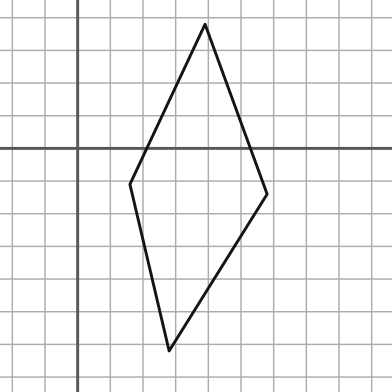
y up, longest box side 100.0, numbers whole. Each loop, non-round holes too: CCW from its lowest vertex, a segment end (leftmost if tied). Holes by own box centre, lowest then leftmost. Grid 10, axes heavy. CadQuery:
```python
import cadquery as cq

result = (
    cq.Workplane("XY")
    .moveTo(28.0, -62.0)
    .lineTo(58.0, -14.0)
    .lineTo(39.0, 38.0)
    .lineTo(16.0, -11.0)
    .close()
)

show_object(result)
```